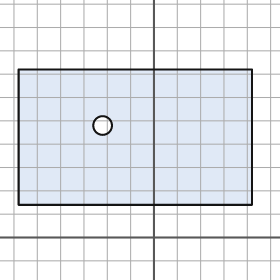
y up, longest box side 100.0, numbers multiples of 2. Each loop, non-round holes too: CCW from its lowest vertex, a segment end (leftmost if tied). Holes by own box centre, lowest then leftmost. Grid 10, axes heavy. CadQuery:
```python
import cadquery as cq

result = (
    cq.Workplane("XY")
    .moveTo(-58.0, 14.0)
    .lineTo(42.0, 14.0)
    .lineTo(42.0, 72.0)
    .lineTo(-58.0, 72.0)
    .close()
    .moveTo(-22.0, 48.0)
    .circle(4.0)
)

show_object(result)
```